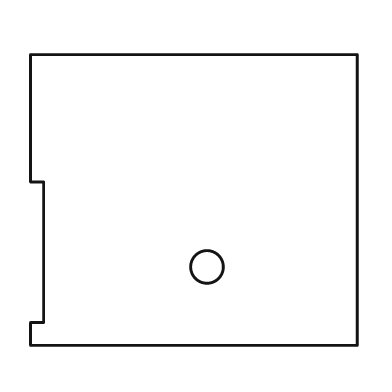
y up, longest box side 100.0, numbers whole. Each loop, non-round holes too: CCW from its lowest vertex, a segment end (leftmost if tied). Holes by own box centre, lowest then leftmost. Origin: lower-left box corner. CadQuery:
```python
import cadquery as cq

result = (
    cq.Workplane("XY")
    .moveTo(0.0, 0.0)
    .lineTo(100.0, 0.0)
    .lineTo(100.0, 89.0)
    .lineTo(0.0, 89.0)
    .lineTo(0.0, 50.0)
    .lineTo(4.0, 50.0)
    .lineTo(4.0, 7.0)
    .lineTo(0.0, 7.0)
    .close()
    .moveTo(54.0, 24.0)
    .circle(5.0)
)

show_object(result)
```